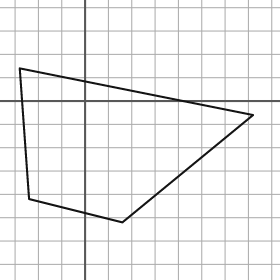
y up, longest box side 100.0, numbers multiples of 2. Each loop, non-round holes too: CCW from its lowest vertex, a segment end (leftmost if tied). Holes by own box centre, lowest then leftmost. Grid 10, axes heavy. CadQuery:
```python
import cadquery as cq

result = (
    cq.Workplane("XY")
    .moveTo(16.0, -52.0)
    .lineTo(72.0, -6.0)
    .lineTo(-28.0, 14.0)
    .lineTo(-24.0, -42.0)
    .close()
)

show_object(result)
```